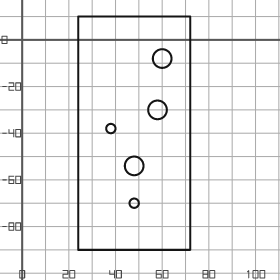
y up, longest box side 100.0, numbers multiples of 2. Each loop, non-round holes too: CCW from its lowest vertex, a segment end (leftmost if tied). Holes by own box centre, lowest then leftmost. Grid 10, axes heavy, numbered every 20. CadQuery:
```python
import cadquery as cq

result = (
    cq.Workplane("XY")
    .moveTo(24.0, -90.0)
    .lineTo(72.0, -90.0)
    .lineTo(72.0, 10.0)
    .lineTo(24.0, 10.0)
    .close()
    .moveTo(48.0, -70.0)
    .circle(2.0)
    .moveTo(48.0, -54.0)
    .circle(4.0)
    .moveTo(38.0, -38.0)
    .circle(2.0)
    .moveTo(58.0, -30.0)
    .circle(4.0)
    .moveTo(60.0, -8.0)
    .circle(4.0)
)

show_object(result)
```